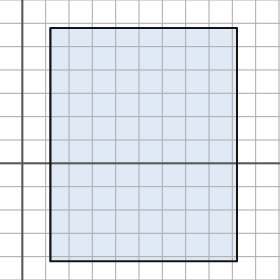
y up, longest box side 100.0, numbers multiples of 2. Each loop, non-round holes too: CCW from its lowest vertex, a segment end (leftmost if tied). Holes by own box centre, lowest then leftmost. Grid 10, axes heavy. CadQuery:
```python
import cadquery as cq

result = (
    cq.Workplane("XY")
    .moveTo(12.0, -42.0)
    .lineTo(92.0, -42.0)
    .lineTo(92.0, 58.0)
    .lineTo(12.0, 58.0)
    .close()
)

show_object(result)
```